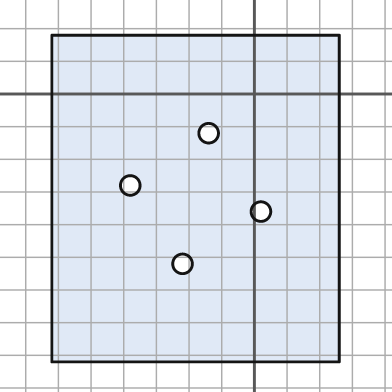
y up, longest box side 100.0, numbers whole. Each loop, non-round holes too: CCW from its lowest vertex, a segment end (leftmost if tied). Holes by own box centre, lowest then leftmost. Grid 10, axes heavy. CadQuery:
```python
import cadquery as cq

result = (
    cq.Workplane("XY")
    .moveTo(-62.0, -82.0)
    .lineTo(26.0, -82.0)
    .lineTo(26.0, 18.0)
    .lineTo(-62.0, 18.0)
    .close()
    .moveTo(-22.0, -52.0)
    .circle(3.0)
    .moveTo(2.0, -36.0)
    .circle(3.0)
    .moveTo(-38.0, -28.0)
    .circle(3.0)
    .moveTo(-14.0, -12.0)
    .circle(3.0)
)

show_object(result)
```